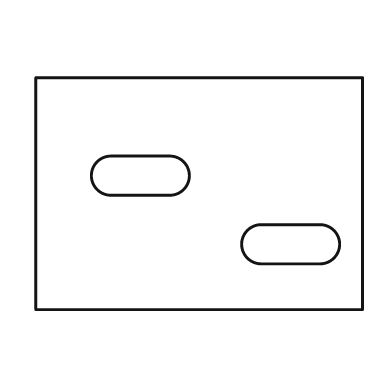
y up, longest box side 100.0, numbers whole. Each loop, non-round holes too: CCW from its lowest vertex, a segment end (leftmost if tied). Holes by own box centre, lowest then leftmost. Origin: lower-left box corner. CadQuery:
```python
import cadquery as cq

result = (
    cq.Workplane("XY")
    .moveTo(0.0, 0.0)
    .lineTo(100.0, 0.0)
    .lineTo(100.0, 71.0)
    .lineTo(0.0, 71.0)
    .close()
    .moveTo(69.0, 14.0)
    .lineTo(87.0, 14.0)
    .threePointArc((93.0, 20.0), (87.0, 26.0))
    .lineTo(69.0, 26.0)
    .threePointArc((63.0, 20.0), (69.0, 14.0))
    .close()
    .moveTo(23.0, 35.0)
    .lineTo(41.0, 35.0)
    .threePointArc((47.0, 41.0), (41.0, 47.0))
    .lineTo(23.0, 47.0)
    .threePointArc((17.0, 41.0), (23.0, 35.0))
    .close()
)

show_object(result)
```